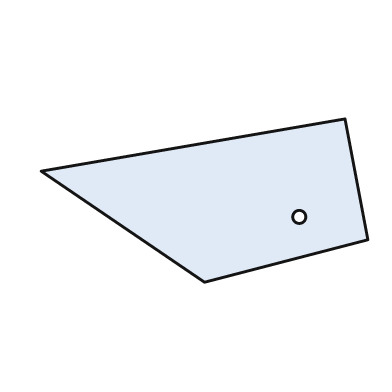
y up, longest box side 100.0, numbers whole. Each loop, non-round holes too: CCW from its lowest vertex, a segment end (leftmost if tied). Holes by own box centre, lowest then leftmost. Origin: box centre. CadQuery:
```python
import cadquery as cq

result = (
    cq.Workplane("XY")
    .moveTo(0.0, -25.0)
    .lineTo(50.0, -12.0)
    .lineTo(43.0, 25.0)
    .lineTo(-50.0, 9.0)
    .close()
    .moveTo(29.0, -5.0)
    .circle(2.0)
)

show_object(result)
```